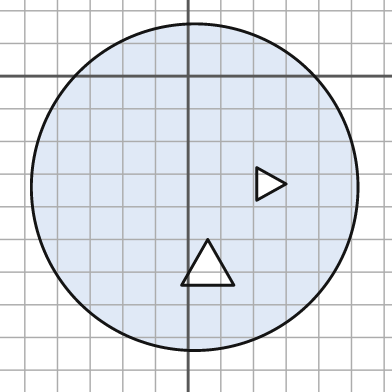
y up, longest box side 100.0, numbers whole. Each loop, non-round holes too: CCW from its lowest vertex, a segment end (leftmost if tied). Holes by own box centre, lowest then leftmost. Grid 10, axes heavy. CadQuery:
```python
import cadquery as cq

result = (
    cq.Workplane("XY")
    .moveTo(2.0, -34.0)
    .circle(50.0)
    .moveTo(-2.0, -64.0)
    .lineTo(14.0, -64.0)
    .lineTo(6.0, -50.0)
    .close()
    .moveTo(21.0, -38.0)
    .lineTo(30.0, -33.0)
    .lineTo(21.0, -28.0)
    .close()
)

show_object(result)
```